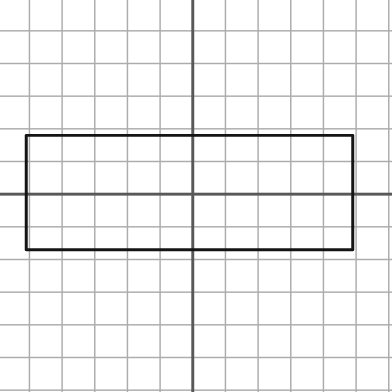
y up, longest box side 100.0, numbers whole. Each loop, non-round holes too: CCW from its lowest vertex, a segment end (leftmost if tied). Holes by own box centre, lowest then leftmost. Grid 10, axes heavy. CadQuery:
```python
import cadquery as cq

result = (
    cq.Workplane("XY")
    .moveTo(-51.0, -17.0)
    .lineTo(49.0, -17.0)
    .lineTo(49.0, 18.0)
    .lineTo(-51.0, 18.0)
    .close()
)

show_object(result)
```